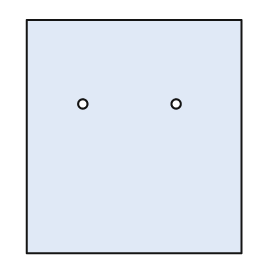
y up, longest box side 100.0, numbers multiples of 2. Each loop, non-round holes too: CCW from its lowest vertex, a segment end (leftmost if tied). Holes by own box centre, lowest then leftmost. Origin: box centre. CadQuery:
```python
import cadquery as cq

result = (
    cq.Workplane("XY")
    .moveTo(-46.0, -50.0)
    .lineTo(46.0, -50.0)
    .lineTo(46.0, 50.0)
    .lineTo(-46.0, 50.0)
    .close()
    .moveTo(-22.0, 14.0)
    .circle(2.0)
    .moveTo(18.0, 14.0)
    .circle(2.0)
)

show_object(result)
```